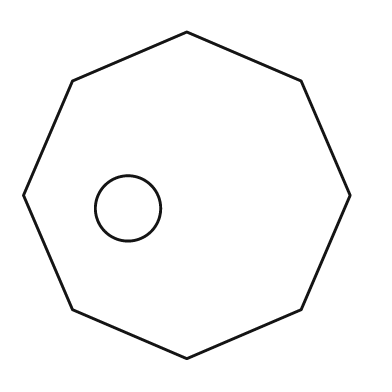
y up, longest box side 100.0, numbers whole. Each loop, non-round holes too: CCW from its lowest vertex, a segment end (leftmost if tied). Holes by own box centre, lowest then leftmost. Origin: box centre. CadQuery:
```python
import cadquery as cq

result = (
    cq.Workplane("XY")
    .moveTo(0.0, -50.0)
    .lineTo(35.0, -35.0)
    .lineTo(50.0, 0.0)
    .lineTo(35.0, 35.0)
    .lineTo(0.0, 50.0)
    .lineTo(-35.0, 35.0)
    .lineTo(-50.0, 0.0)
    .lineTo(-35.0, -35.0)
    .close()
    .moveTo(-18.0, -4.0)
    .circle(10.0)
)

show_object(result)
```